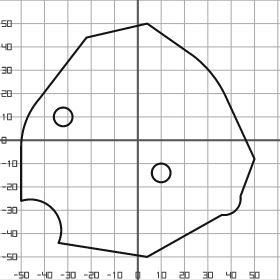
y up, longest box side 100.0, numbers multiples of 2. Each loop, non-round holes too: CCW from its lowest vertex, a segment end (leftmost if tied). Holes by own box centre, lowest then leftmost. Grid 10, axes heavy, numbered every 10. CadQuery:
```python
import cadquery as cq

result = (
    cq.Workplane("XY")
    .moveTo(4.0, -50.0)
    .lineTo(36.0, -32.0)
    .threePointArc((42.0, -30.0), (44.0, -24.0))
    .lineTo(50.0, -8.0)
    .lineTo(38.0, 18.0)
    .threePointArc((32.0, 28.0), (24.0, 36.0))
    .lineTo(4.0, 50.0)
    .lineTo(-22.0, 44.0)
    .lineTo(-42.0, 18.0)
    .threePointArc((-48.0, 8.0), (-50.0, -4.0))
    .lineTo(-50.0, -26.0)
    .threePointArc((-36.0, -30.0), (-34.0, -44.0))
    .close()
    .moveTo(10.0, -14.0)
    .circle(4.0)
    .moveTo(-32.0, 10.0)
    .circle(4.0)
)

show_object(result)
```